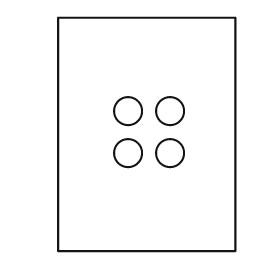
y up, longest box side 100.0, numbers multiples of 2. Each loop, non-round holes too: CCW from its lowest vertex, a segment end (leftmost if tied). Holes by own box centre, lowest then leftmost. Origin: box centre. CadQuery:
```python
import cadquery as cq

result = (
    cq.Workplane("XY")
    .moveTo(-38.0, -50.0)
    .lineTo(38.0, -50.0)
    .lineTo(38.0, 50.0)
    .lineTo(-38.0, 50.0)
    .close()
    .moveTo(-8.0, -8.0)
    .circle(6.0)
    .moveTo(10.0, -8.0)
    .circle(6.0)
    .moveTo(-8.0, 10.0)
    .circle(6.0)
    .moveTo(10.0, 10.0)
    .circle(6.0)
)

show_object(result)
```